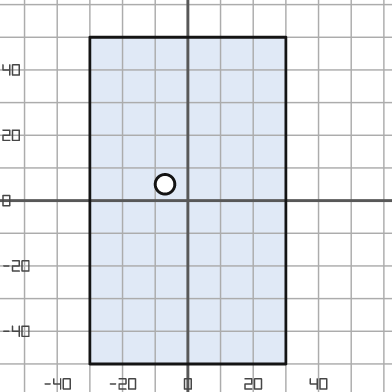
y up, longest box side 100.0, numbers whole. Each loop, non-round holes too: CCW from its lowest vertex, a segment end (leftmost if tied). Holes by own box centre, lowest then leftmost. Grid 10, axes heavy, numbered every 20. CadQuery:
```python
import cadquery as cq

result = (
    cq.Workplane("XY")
    .moveTo(-30.0, -50.0)
    .lineTo(30.0, -50.0)
    .lineTo(30.0, 50.0)
    .lineTo(-30.0, 50.0)
    .close()
    .moveTo(-7.0, 5.0)
    .circle(3.0)
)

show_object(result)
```